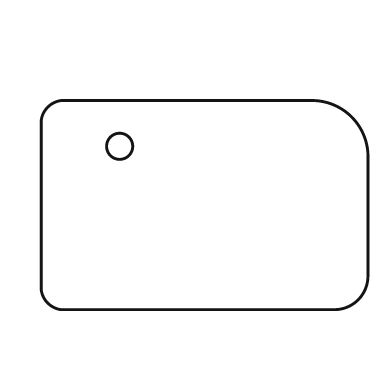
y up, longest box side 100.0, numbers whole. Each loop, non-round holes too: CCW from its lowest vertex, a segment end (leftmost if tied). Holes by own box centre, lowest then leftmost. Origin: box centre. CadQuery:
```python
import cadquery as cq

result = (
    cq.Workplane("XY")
    .moveTo(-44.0, -32.0)
    .lineTo(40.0, -32.0)
    .threePointArc((47.0, -29.0), (50.0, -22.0))
    .lineTo(50.0, 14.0)
    .threePointArc((45.0, 27.0), (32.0, 32.0))
    .lineTo(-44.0, 32.0)
    .threePointArc((-48.0, 30.0), (-50.0, 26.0))
    .lineTo(-50.0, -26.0)
    .threePointArc((-48.0, -30.0), (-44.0, -32.0))
    .close()
    .moveTo(-26.0, 18.0)
    .circle(4.0)
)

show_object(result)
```